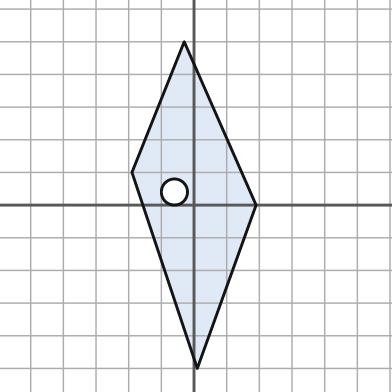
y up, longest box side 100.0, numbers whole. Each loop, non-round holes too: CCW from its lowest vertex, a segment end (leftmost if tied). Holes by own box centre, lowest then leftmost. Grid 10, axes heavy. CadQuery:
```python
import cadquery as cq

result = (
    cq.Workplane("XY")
    .moveTo(1.0, -50.0)
    .lineTo(19.0, 0.0)
    .lineTo(-3.0, 50.0)
    .lineTo(-19.0, 10.0)
    .close()
    .moveTo(-6.0, 4.0)
    .circle(4.0)
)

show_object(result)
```